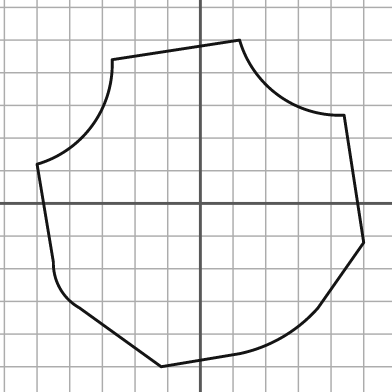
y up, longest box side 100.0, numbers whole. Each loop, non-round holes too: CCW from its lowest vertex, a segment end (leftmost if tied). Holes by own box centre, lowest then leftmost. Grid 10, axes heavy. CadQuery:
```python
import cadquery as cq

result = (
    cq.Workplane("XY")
    .moveTo(-12.0, -50.0)
    .lineTo(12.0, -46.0)
    .threePointArc((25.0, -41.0), (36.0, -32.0))
    .lineTo(50.0, -12.0)
    .lineTo(44.0, 27.0)
    .threePointArc((24.0, 33.0), (12.0, 50.0))
    .lineTo(-27.0, 44.0)
    .threePointArc((-33.0, 24.0), (-50.0, 12.0))
    .lineTo(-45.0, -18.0)
    .threePointArc((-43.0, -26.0), (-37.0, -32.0))
    .close()
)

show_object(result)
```